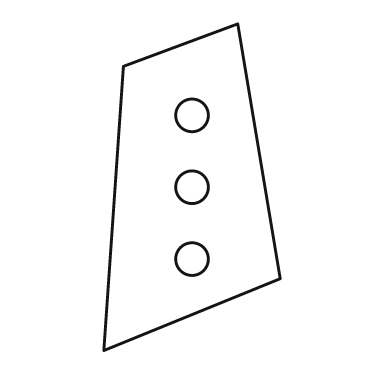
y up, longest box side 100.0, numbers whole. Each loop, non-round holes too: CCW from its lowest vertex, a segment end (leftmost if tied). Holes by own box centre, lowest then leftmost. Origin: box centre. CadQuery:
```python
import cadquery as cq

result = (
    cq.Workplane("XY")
    .moveTo(-27.0, -50.0)
    .lineTo(27.0, -28.0)
    .lineTo(14.0, 50.0)
    .lineTo(-21.0, 37.0)
    .close()
    .moveTo(0.0, -22.0)
    .circle(5.0)
    .moveTo(0.0, 0.0)
    .circle(5.0)
    .moveTo(0.0, 22.0)
    .circle(5.0)
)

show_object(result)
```